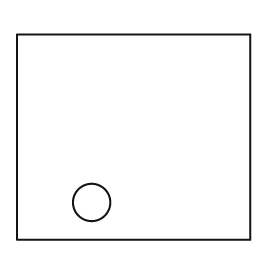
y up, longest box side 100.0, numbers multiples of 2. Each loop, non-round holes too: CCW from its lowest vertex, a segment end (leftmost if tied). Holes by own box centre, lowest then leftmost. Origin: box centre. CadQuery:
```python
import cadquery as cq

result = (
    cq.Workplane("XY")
    .moveTo(-50.0, -44.0)
    .lineTo(50.0, -44.0)
    .lineTo(50.0, 44.0)
    .lineTo(-50.0, 44.0)
    .close()
    .moveTo(-18.0, -28.0)
    .circle(8.0)
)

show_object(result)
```